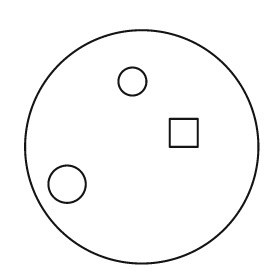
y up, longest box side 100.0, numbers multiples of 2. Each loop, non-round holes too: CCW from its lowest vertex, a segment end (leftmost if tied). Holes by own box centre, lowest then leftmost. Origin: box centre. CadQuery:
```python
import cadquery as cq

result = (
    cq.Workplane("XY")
    .moveTo(0.0, 0.0)
    .circle(50.0)
    .moveTo(-32.0, -16.0)
    .circle(8.0)
    .moveTo(12.0, 0.0)
    .lineTo(24.0, 0.0)
    .lineTo(24.0, 12.0)
    .lineTo(12.0, 12.0)
    .close()
    .moveTo(-4.0, 28.0)
    .circle(6.0)
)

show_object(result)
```